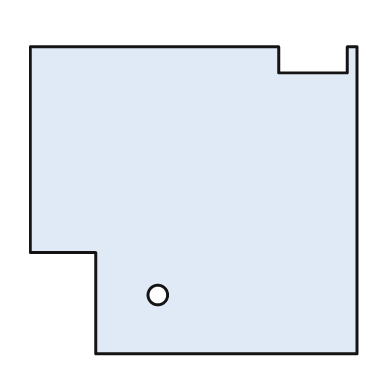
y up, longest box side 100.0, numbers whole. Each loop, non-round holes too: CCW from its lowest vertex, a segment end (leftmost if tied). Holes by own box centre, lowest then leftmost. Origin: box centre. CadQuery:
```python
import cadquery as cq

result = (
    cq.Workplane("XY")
    .moveTo(-30.0, -47.0)
    .lineTo(50.0, -47.0)
    .lineTo(50.0, 47.0)
    .lineTo(47.0, 47.0)
    .lineTo(47.0, 39.0)
    .lineTo(26.0, 39.0)
    .lineTo(26.0, 47.0)
    .lineTo(-50.0, 47.0)
    .lineTo(-50.0, -16.0)
    .lineTo(-30.0, -16.0)
    .close()
    .moveTo(-11.0, -29.0)
    .circle(3.0)
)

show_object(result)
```